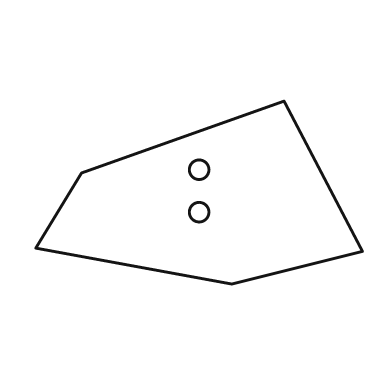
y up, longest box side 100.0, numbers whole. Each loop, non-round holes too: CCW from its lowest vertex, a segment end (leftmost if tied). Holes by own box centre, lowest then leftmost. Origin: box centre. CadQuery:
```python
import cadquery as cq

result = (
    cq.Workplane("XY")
    .moveTo(10.0, -28.0)
    .lineTo(50.0, -18.0)
    .lineTo(26.0, 28.0)
    .lineTo(-36.0, 6.0)
    .lineTo(-50.0, -17.0)
    .close()
    .moveTo(0.0, -6.0)
    .circle(3.0)
    .moveTo(0.0, 7.0)
    .circle(3.0)
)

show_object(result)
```